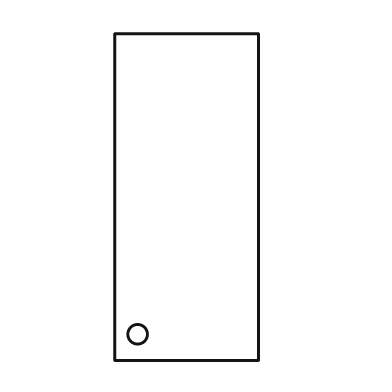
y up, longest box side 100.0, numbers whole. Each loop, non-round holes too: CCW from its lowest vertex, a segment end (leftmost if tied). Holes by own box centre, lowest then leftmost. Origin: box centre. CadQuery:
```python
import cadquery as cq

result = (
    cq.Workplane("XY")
    .moveTo(-22.0, -50.0)
    .lineTo(22.0, -50.0)
    .lineTo(22.0, 50.0)
    .lineTo(-22.0, 50.0)
    .close()
    .moveTo(-15.0, -42.0)
    .circle(3.0)
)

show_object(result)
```